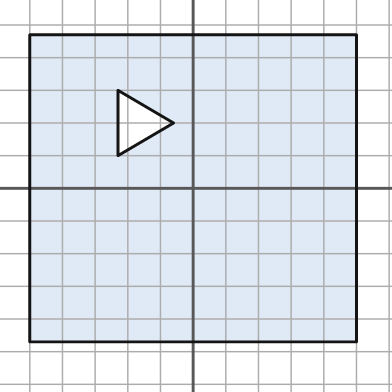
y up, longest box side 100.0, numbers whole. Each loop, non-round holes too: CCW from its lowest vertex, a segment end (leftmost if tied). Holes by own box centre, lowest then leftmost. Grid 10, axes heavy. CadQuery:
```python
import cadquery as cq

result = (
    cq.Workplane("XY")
    .moveTo(-50.0, -47.0)
    .lineTo(50.0, -47.0)
    .lineTo(50.0, 47.0)
    .lineTo(-50.0, 47.0)
    .close()
    .moveTo(-23.0, 10.0)
    .lineTo(-6.0, 20.0)
    .lineTo(-23.0, 30.0)
    .close()
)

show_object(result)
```